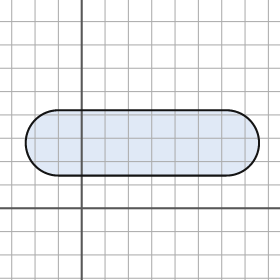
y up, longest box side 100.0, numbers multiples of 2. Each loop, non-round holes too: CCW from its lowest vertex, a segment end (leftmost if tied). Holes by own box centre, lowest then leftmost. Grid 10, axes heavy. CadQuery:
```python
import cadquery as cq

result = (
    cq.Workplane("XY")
    .moveTo(-10.0, 14.0)
    .lineTo(62.0, 14.0)
    .threePointArc((76.0, 28.0), (62.0, 42.0))
    .lineTo(-10.0, 42.0)
    .threePointArc((-24.0, 28.0), (-10.0, 14.0))
    .close()
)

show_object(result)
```